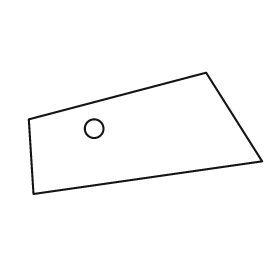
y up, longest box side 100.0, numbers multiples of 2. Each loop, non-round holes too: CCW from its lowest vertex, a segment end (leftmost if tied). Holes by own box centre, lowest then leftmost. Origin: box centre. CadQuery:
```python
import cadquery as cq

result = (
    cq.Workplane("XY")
    .moveTo(-48.0, -26.0)
    .lineTo(50.0, -12.0)
    .lineTo(26.0, 26.0)
    .lineTo(-50.0, 6.0)
    .close()
    .moveTo(-22.0, 2.0)
    .circle(4.0)
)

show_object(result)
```